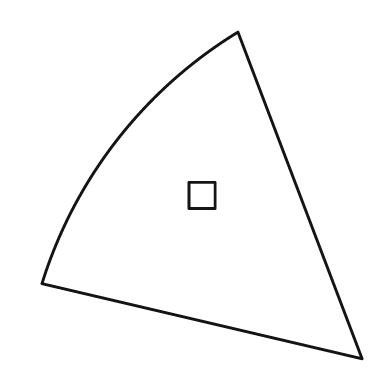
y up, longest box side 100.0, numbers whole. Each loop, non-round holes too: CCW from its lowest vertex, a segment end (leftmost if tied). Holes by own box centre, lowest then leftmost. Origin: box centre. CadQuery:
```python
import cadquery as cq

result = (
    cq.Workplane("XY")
    .moveTo(49.0, -50.0)
    .lineTo(11.0, 50.0)
    .threePointArc((-26.0, 17.0), (-49.0, -27.0))
    .close()
    .moveTo(-4.0, -4.0)
    .lineTo(4.0, -4.0)
    .lineTo(4.0, 4.0)
    .lineTo(-4.0, 4.0)
    .close()
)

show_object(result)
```